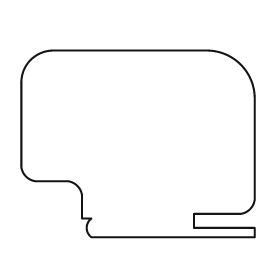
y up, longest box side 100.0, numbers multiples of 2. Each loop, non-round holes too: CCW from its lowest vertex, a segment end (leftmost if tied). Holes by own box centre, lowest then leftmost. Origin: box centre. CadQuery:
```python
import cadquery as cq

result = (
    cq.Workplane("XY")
    .moveTo(-20.0, -40.0)
    .lineTo(50.0, -40.0)
    .lineTo(50.0, -36.0)
    .lineTo(24.0, -36.0)
    .lineTo(24.0, -30.0)
    .lineTo(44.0, -30.0)
    .threePointArc((48.0, -28.0), (50.0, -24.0))
    .lineTo(50.0, 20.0)
    .threePointArc((44.0, 34.0), (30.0, 40.0))
    .lineTo(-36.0, 40.0)
    .threePointArc((-46.0, 36.0), (-50.0, 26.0))
    .lineTo(-50.0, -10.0)
    .threePointArc((-48.0, -14.0), (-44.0, -16.0))
    .lineTo(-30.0, -16.0)
    .threePointArc((-26.0, -18.0), (-24.0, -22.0))
    .lineTo(-24.0, -32.0)
    .lineTo(-20.0, -32.0)
    .threePointArc((-22.0, -36.0), (-20.0, -40.0))
    .close()
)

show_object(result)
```